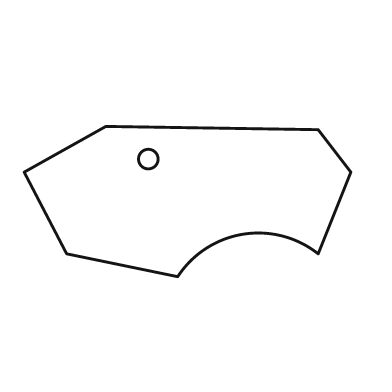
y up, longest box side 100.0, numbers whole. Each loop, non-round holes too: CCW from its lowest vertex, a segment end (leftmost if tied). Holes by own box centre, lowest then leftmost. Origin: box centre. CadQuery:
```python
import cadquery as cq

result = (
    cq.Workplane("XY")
    .moveTo(-3.0, -23.0)
    .threePointArc((17.0, -10.0), (40.0, -16.0))
    .lineTo(50.0, 9.0)
    .lineTo(40.0, 22.0)
    .lineTo(-25.0, 23.0)
    .lineTo(-50.0, 9.0)
    .lineTo(-37.0, -16.0)
    .close()
    .moveTo(-12.0, 13.0)
    .circle(3.0)
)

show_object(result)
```